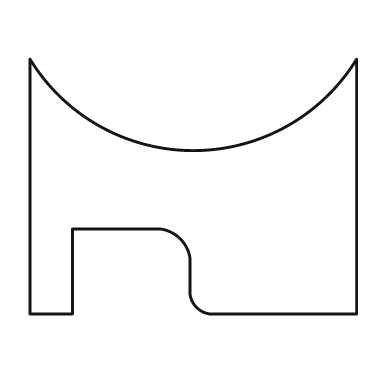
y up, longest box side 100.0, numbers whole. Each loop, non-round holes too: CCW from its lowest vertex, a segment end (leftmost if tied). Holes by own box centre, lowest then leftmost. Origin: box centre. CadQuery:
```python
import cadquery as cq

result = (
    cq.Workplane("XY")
    .moveTo(-50.0, -39.0)
    .lineTo(-37.0, -39.0)
    .lineTo(-37.0, -13.0)
    .lineTo(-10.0, -13.0)
    .threePointArc((-4.0, -16.0), (-1.0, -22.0))
    .lineTo(-1.0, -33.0)
    .threePointArc((1.0, -37.0), (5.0, -39.0))
    .lineTo(50.0, -39.0)
    .lineTo(50.0, 39.0)
    .threePointArc((0.0, 11.0), (-50.0, 39.0))
    .close()
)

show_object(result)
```